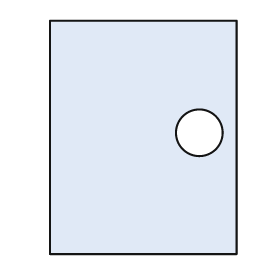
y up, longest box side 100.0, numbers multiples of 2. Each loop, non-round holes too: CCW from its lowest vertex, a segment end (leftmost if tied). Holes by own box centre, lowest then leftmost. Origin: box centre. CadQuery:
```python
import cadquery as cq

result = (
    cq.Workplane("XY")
    .moveTo(-40.0, -50.0)
    .lineTo(40.0, -50.0)
    .lineTo(40.0, 50.0)
    .lineTo(-40.0, 50.0)
    .close()
    .moveTo(24.0, 2.0)
    .circle(10.0)
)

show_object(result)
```